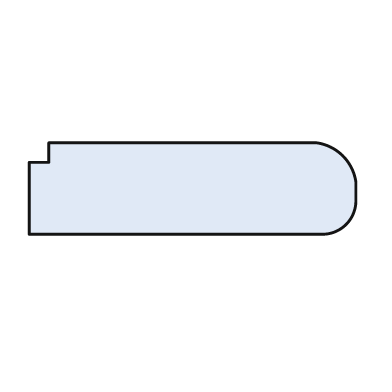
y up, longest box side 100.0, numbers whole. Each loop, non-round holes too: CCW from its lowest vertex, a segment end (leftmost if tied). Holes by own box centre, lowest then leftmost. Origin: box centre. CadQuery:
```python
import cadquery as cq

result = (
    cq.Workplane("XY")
    .moveTo(-50.0, -14.0)
    .lineTo(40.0, -14.0)
    .threePointArc((47.0, -11.0), (50.0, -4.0))
    .lineTo(50.0, 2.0)
    .threePointArc((46.0, 10.0), (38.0, 14.0))
    .lineTo(-44.0, 14.0)
    .lineTo(-44.0, 8.0)
    .lineTo(-50.0, 8.0)
    .close()
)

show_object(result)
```